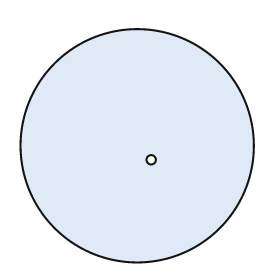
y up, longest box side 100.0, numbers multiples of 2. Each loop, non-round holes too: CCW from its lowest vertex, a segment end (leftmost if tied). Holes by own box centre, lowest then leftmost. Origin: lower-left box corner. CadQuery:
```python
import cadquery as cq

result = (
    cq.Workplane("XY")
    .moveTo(50.0, 50.0)
    .circle(50.0)
    .moveTo(56.0, 44.0)
    .circle(2.0)
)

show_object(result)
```